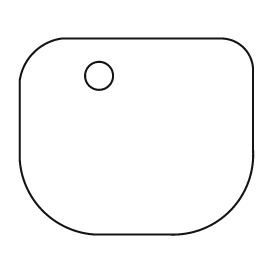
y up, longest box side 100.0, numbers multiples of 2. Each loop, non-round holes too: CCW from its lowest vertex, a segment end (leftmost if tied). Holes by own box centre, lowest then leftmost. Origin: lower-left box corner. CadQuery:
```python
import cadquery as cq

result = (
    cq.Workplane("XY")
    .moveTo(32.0, 0.0)
    .lineTo(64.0, 0.0)
    .threePointArc((90.0, 10.0), (100.0, 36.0))
    .lineTo(100.0, 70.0)
    .threePointArc((96.0, 80.0), (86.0, 84.0))
    .lineTo(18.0, 84.0)
    .threePointArc((6.0, 78.0), (0.0, 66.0))
    .lineTo(0.0, 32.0)
    .threePointArc((10.0, 10.0), (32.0, 0.0))
    .close()
    .moveTo(34.0, 68.0)
    .circle(6.0)
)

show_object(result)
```